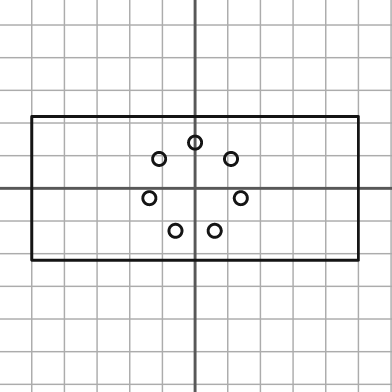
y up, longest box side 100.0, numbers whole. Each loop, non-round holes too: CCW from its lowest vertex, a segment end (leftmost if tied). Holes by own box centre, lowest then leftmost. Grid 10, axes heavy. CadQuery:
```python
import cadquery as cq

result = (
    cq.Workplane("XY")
    .moveTo(-50.0, -22.0)
    .lineTo(50.0, -22.0)
    .lineTo(50.0, 22.0)
    .lineTo(-50.0, 22.0)
    .close()
    .moveTo(-6.0, -13.0)
    .circle(2.0)
    .moveTo(6.0, -13.0)
    .circle(2.0)
    .moveTo(-14.0, -3.0)
    .circle(2.0)
    .moveTo(14.0, -3.0)
    .circle(2.0)
    .moveTo(-11.0, 9.0)
    .circle(2.0)
    .moveTo(11.0, 9.0)
    .circle(2.0)
    .moveTo(0.0, 14.0)
    .circle(2.0)
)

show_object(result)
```